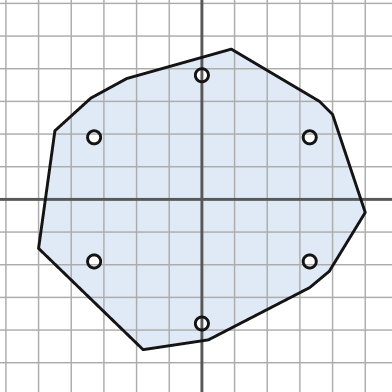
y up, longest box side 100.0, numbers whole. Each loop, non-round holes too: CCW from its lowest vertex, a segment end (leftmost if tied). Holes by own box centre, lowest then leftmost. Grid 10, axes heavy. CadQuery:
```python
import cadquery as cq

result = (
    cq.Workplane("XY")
    .moveTo(-18.0, -46.0)
    .lineTo(2.0, -43.0)
    .lineTo(33.0, -27.0)
    .lineTo(39.0, -22.0)
    .lineTo(50.0, -4.0)
    .lineTo(40.0, 26.0)
    .lineTo(36.0, 30.0)
    .lineTo(9.0, 46.0)
    .lineTo(-23.0, 37.0)
    .lineTo(-34.0, 31.0)
    .lineTo(-45.0, 21.0)
    .lineTo(-50.0, -15.0)
    .close()
    .moveTo(0.0, -38.0)
    .circle(2.0)
    .moveTo(-33.0, -19.0)
    .circle(2.0)
    .moveTo(33.0, -19.0)
    .circle(2.0)
    .moveTo(-33.0, 19.0)
    .circle(2.0)
    .moveTo(33.0, 19.0)
    .circle(2.0)
    .moveTo(0.0, 38.0)
    .circle(2.0)
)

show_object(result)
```